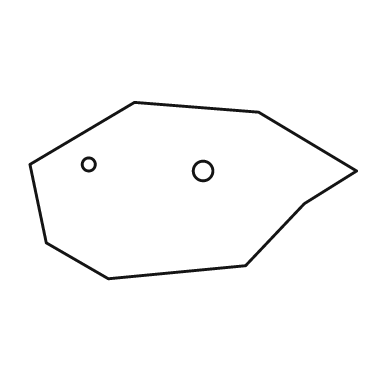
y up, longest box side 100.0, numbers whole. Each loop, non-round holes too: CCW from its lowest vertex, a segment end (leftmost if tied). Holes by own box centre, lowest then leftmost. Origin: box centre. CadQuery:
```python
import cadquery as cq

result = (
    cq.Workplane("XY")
    .moveTo(-26.0, -27.0)
    .lineTo(16.0, -23.0)
    .lineTo(34.0, -4.0)
    .lineTo(50.0, 6.0)
    .lineTo(20.0, 24.0)
    .lineTo(-18.0, 27.0)
    .lineTo(-50.0, 8.0)
    .lineTo(-45.0, -16.0)
    .close()
    .moveTo(3.0, 6.0)
    .circle(3.0)
    .moveTo(-32.0, 8.0)
    .circle(2.0)
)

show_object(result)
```